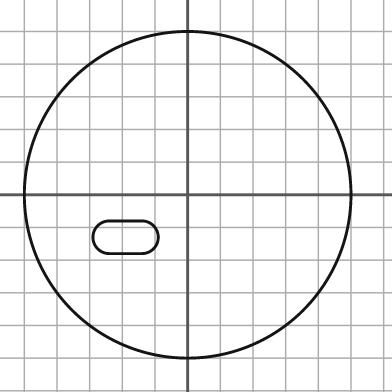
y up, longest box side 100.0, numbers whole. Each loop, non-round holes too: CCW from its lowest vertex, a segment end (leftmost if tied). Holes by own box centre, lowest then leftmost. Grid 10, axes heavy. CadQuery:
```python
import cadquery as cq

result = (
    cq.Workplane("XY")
    .moveTo(0.0, 0.0)
    .circle(50.0)
    .moveTo(-24.0, -18.0)
    .lineTo(-14.0, -18.0)
    .threePointArc((-9.0, -13.0), (-14.0, -8.0))
    .lineTo(-24.0, -8.0)
    .threePointArc((-29.0, -13.0), (-24.0, -18.0))
    .close()
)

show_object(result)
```